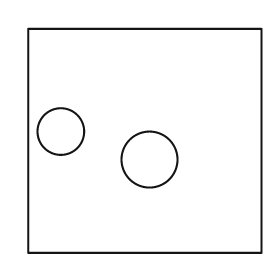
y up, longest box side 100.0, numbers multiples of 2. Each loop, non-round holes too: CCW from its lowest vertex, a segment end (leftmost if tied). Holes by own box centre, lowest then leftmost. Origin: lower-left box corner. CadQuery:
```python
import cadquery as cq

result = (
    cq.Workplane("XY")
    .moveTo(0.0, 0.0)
    .lineTo(100.0, 0.0)
    .lineTo(100.0, 96.0)
    .lineTo(0.0, 96.0)
    .close()
    .moveTo(52.0, 40.0)
    .circle(12.0)
    .moveTo(14.0, 52.0)
    .circle(10.0)
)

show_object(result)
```